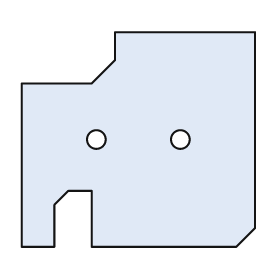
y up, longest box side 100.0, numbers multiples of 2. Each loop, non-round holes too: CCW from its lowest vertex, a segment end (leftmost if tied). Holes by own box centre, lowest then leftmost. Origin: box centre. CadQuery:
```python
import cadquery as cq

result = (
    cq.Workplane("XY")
    .moveTo(-50.0, -46.0)
    .lineTo(-36.0, -46.0)
    .lineTo(-36.0, -28.0)
    .lineTo(-30.0, -22.0)
    .lineTo(-20.0, -22.0)
    .lineTo(-20.0, -46.0)
    .lineTo(42.0, -46.0)
    .lineTo(50.0, -38.0)
    .lineTo(50.0, 46.0)
    .lineTo(-10.0, 46.0)
    .lineTo(-10.0, 34.0)
    .lineTo(-20.0, 24.0)
    .lineTo(-50.0, 24.0)
    .close()
    .moveTo(-18.0, 0.0)
    .circle(4.0)
    .moveTo(18.0, 0.0)
    .circle(4.0)
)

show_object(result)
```